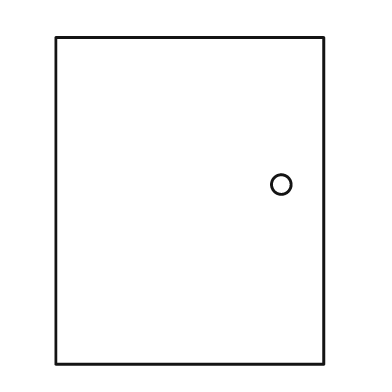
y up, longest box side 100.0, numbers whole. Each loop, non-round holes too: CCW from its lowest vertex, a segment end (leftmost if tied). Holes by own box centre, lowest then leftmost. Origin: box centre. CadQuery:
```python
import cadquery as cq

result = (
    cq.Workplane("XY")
    .moveTo(-41.0, -50.0)
    .lineTo(41.0, -50.0)
    .lineTo(41.0, 50.0)
    .lineTo(-41.0, 50.0)
    .close()
    .moveTo(28.0, 5.0)
    .circle(3.0)
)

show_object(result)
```